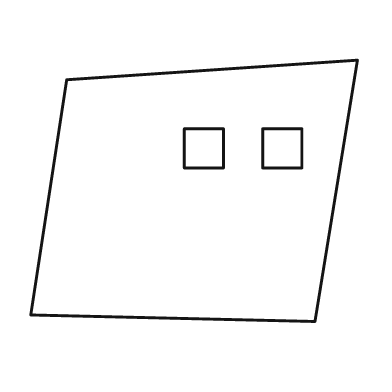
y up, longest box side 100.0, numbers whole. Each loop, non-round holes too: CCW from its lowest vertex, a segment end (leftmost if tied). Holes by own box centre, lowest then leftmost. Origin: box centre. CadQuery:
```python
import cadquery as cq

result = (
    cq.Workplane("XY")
    .moveTo(37.0, -40.0)
    .lineTo(50.0, 40.0)
    .lineTo(-39.0, 34.0)
    .lineTo(-50.0, -38.0)
    .close()
    .moveTo(-3.0, 7.0)
    .lineTo(9.0, 7.0)
    .lineTo(9.0, 19.0)
    .lineTo(-3.0, 19.0)
    .close()
    .moveTo(21.0, 7.0)
    .lineTo(33.0, 7.0)
    .lineTo(33.0, 19.0)
    .lineTo(21.0, 19.0)
    .close()
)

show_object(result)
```